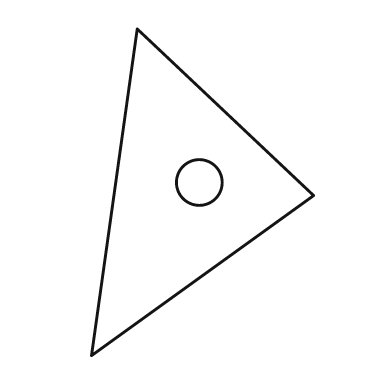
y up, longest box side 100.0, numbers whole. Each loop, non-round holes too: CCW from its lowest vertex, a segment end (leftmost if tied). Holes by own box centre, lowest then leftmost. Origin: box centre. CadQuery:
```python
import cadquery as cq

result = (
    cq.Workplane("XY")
    .moveTo(-34.0, -50.0)
    .lineTo(34.0, -1.0)
    .lineTo(-20.0, 50.0)
    .close()
    .moveTo(-1.0, 3.0)
    .circle(7.0)
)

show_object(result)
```